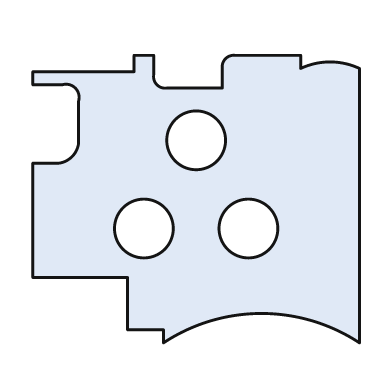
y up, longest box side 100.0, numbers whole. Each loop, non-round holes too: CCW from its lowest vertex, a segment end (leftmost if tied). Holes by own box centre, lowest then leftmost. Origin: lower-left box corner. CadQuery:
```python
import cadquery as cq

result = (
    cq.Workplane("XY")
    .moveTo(40.0, 0.0)
    .threePointArc((70.0, 9.0), (100.0, 0.0))
    .lineTo(100.0, 84.0)
    .threePointArc((91.0, 86.0), (82.0, 84.0))
    .lineTo(82.0, 88.0)
    .lineTo(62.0, 88.0)
    .threePointArc((59.0, 87.0), (58.0, 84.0))
    .lineTo(58.0, 78.0)
    .lineTo(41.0, 78.0)
    .threePointArc((38.0, 79.0), (37.0, 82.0))
    .lineTo(37.0, 88.0)
    .lineTo(31.0, 88.0)
    .lineTo(31.0, 83.0)
    .lineTo(0.0, 83.0)
    .lineTo(0.0, 79.0)
    .lineTo(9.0, 79.0)
    .threePointArc((13.0, 78.0), (14.0, 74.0))
    .lineTo(14.0, 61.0)
    .threePointArc((12.0, 57.0), (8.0, 55.0))
    .lineTo(0.0, 55.0)
    .lineTo(0.0, 20.0)
    .lineTo(29.0, 20.0)
    .lineTo(29.0, 4.0)
    .lineTo(40.0, 4.0)
    .close()
    .moveTo(34.0, 35.0)
    .circle(9.0)
    .moveTo(66.0, 35.0)
    .circle(9.0)
    .moveTo(50.0, 62.0)
    .circle(9.0)
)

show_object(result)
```